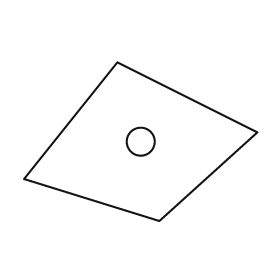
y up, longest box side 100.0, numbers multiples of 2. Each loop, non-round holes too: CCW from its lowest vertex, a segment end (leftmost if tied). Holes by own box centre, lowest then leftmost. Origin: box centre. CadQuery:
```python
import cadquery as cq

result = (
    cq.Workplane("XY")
    .moveTo(8.0, -34.0)
    .lineTo(50.0, 4.0)
    .lineTo(-10.0, 34.0)
    .lineTo(-50.0, -16.0)
    .close()
    .moveTo(0.0, 0.0)
    .circle(6.0)
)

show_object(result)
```